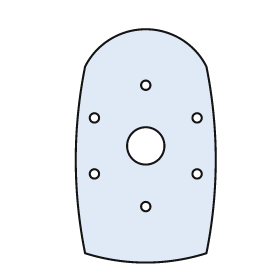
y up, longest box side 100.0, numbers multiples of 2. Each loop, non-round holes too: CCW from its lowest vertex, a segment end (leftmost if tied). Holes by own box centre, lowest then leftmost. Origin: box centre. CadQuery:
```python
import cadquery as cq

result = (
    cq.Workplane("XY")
    .moveTo(-26.0, -46.0)
    .threePointArc((0.0, -50.0), (26.0, -46.0))
    .threePointArc((30.0, -6.0), (26.0, 34.0))
    .threePointArc((0.0, 50.0), (-26.0, 34.0))
    .threePointArc((-30.0, -6.0), (-26.0, -46.0))
    .close()
    .moveTo(0.0, -26.0)
    .circle(2.0)
    .moveTo(-22.0, -12.0)
    .circle(2.0)
    .moveTo(22.0, -12.0)
    .circle(2.0)
    .moveTo(0.0, 0.0)
    .circle(8.0)
    .moveTo(-22.0, 12.0)
    .circle(2.0)
    .moveTo(22.0, 12.0)
    .circle(2.0)
    .moveTo(0.0, 26.0)
    .circle(2.0)
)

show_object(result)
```